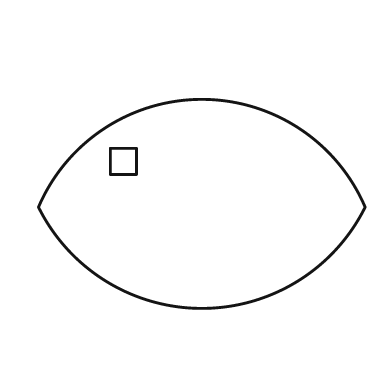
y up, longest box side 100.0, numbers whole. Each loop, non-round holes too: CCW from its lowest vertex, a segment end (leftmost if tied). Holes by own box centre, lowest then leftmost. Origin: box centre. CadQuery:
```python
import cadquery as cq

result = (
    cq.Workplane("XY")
    .moveTo(-50.0, -1.0)
    .threePointArc((0.0, -32.0), (50.0, -1.0))
    .threePointArc((0.0, 32.0), (-50.0, -1.0))
    .close()
    .moveTo(-28.0, 9.0)
    .lineTo(-20.0, 9.0)
    .lineTo(-20.0, 17.0)
    .lineTo(-28.0, 17.0)
    .close()
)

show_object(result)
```